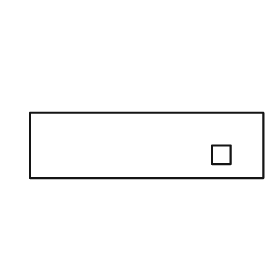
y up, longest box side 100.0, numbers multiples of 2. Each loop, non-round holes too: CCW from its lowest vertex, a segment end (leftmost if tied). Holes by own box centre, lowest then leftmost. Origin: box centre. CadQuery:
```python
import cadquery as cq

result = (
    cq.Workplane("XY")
    .moveTo(-50.0, -14.0)
    .lineTo(50.0, -14.0)
    .lineTo(50.0, 14.0)
    .lineTo(-50.0, 14.0)
    .close()
    .moveTo(28.0, -8.0)
    .lineTo(36.0, -8.0)
    .lineTo(36.0, 0.0)
    .lineTo(28.0, 0.0)
    .close()
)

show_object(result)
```